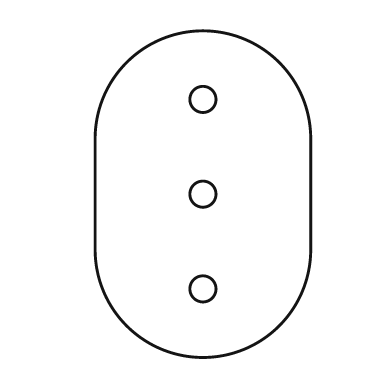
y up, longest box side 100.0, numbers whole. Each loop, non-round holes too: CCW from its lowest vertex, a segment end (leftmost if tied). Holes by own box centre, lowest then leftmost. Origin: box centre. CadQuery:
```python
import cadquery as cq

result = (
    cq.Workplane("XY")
    .moveTo(-33.0, -17.0)
    .threePointArc((0.0, -50.0), (33.0, -17.0))
    .lineTo(33.0, 17.0)
    .threePointArc((0.0, 50.0), (-33.0, 17.0))
    .close()
    .moveTo(0.0, -29.0)
    .circle(4.0)
    .moveTo(0.0, 0.0)
    .circle(4.0)
    .moveTo(0.0, 29.0)
    .circle(4.0)
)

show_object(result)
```